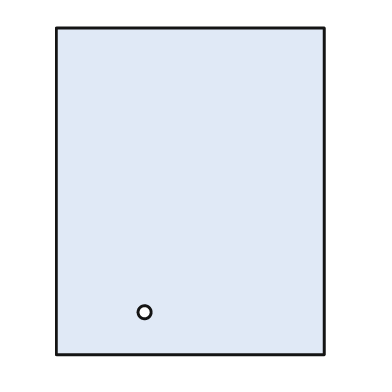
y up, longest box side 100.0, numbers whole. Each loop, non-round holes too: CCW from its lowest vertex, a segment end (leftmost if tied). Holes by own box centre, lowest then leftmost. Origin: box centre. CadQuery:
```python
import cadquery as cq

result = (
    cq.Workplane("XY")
    .moveTo(-41.0, -50.0)
    .lineTo(41.0, -50.0)
    .lineTo(41.0, 50.0)
    .lineTo(-41.0, 50.0)
    .close()
    .moveTo(-14.0, -37.0)
    .circle(2.0)
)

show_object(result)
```